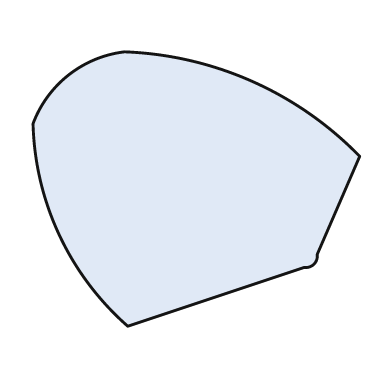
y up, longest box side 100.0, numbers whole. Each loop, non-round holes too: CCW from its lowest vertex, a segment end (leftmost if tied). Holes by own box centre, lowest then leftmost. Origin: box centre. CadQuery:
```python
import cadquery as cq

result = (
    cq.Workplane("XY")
    .moveTo(-21.0, -42.0)
    .lineTo(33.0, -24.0)
    .threePointArc((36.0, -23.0), (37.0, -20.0))
    .lineTo(50.0, 10.0)
    .threePointArc((17.0, 33.0), (-22.0, 42.0))
    .threePointArc((-39.0, 35.0), (-50.0, 20.0))
    .threePointArc((-42.0, -14.0), (-21.0, -42.0))
    .close()
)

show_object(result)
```